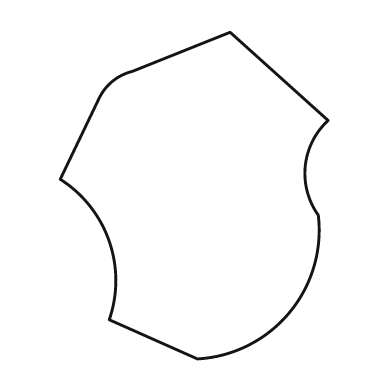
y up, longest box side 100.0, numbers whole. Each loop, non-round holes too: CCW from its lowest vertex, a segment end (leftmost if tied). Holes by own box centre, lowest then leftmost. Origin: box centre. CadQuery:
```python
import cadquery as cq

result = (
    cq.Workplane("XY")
    .moveTo(1.0, -50.0)
    .threePointArc((29.0, -36.0), (38.0, -6.0))
    .threePointArc((34.0, 9.0), (41.0, 23.0))
    .lineTo(11.0, 50.0)
    .lineTo(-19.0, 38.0)
    .threePointArc((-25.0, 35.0), (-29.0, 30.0))
    .lineTo(-41.0, 5.0)
    .threePointArc((-26.0, -14.0), (-26.0, -38.0))
    .close()
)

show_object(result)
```